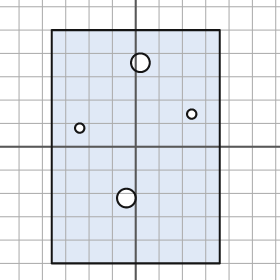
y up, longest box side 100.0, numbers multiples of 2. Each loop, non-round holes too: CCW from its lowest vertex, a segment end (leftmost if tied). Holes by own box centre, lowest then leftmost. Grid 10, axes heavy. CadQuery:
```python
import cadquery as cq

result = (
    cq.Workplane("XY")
    .moveTo(-36.0, -50.0)
    .lineTo(36.0, -50.0)
    .lineTo(36.0, 50.0)
    .lineTo(-36.0, 50.0)
    .close()
    .moveTo(-4.0, -22.0)
    .circle(4.0)
    .moveTo(-24.0, 8.0)
    .circle(2.0)
    .moveTo(24.0, 14.0)
    .circle(2.0)
    .moveTo(2.0, 36.0)
    .circle(4.0)
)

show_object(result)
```